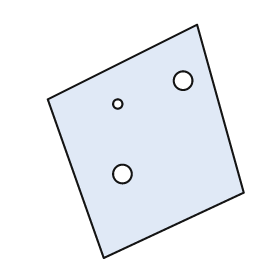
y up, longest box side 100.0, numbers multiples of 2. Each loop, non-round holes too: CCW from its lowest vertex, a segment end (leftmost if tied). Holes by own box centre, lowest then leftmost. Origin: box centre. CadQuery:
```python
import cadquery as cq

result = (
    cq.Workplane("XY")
    .moveTo(-18.0, -50.0)
    .lineTo(42.0, -22.0)
    .lineTo(22.0, 50.0)
    .lineTo(-42.0, 18.0)
    .close()
    .moveTo(-10.0, -14.0)
    .circle(4.0)
    .moveTo(-12.0, 16.0)
    .circle(2.0)
    .moveTo(16.0, 26.0)
    .circle(4.0)
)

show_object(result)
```